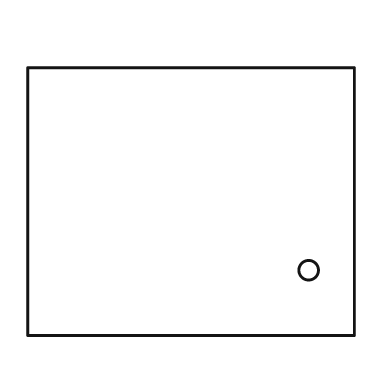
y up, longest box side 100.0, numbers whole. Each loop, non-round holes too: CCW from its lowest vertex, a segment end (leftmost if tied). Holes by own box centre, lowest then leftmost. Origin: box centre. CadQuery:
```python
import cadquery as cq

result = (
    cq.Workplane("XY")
    .moveTo(-50.0, -41.0)
    .lineTo(50.0, -41.0)
    .lineTo(50.0, 41.0)
    .lineTo(-50.0, 41.0)
    .close()
    .moveTo(36.0, -21.0)
    .circle(3.0)
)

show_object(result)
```